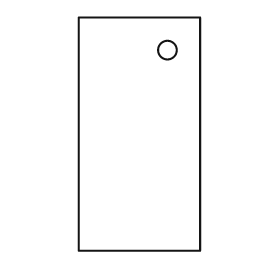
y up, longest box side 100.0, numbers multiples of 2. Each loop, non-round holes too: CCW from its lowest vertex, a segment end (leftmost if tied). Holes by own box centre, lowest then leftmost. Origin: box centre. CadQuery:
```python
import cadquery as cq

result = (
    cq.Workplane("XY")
    .moveTo(-26.0, -50.0)
    .lineTo(26.0, -50.0)
    .lineTo(26.0, 50.0)
    .lineTo(-26.0, 50.0)
    .close()
    .moveTo(12.0, 36.0)
    .circle(4.0)
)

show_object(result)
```